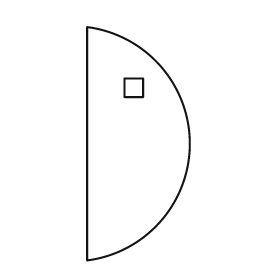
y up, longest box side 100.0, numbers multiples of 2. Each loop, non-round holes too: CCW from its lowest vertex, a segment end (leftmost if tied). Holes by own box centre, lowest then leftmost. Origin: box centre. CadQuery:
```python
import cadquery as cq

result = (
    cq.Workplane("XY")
    .moveTo(-22.0, -50.0)
    .threePointArc((22.0, 0.0), (-22.0, 50.0))
    .close()
    .moveTo(-6.0, 20.0)
    .lineTo(2.0, 20.0)
    .lineTo(2.0, 28.0)
    .lineTo(-6.0, 28.0)
    .close()
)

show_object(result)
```